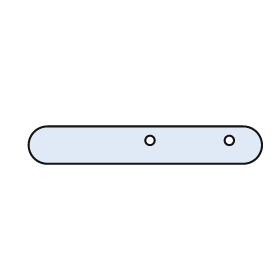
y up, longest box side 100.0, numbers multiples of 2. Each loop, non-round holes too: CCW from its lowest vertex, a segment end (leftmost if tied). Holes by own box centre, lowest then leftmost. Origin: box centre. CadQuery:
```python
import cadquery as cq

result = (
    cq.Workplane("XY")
    .moveTo(-42.0, -8.0)
    .lineTo(42.0, -8.0)
    .threePointArc((50.0, 0.0), (42.0, 8.0))
    .lineTo(-42.0, 8.0)
    .threePointArc((-50.0, 0.0), (-42.0, -8.0))
    .close()
    .moveTo(2.0, 2.0)
    .circle(2.0)
    .moveTo(36.0, 2.0)
    .circle(2.0)
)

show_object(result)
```